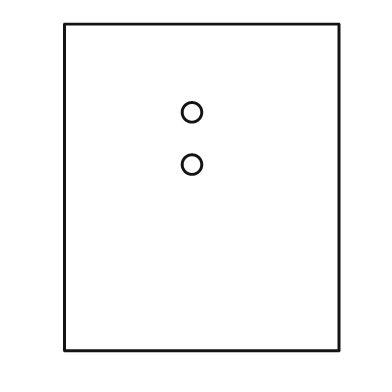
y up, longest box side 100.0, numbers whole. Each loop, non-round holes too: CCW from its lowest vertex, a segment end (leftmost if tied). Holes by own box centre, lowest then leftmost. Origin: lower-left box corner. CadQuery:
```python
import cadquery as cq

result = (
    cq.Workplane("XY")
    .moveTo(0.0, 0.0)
    .lineTo(84.0, 0.0)
    .lineTo(84.0, 100.0)
    .lineTo(0.0, 100.0)
    .close()
    .moveTo(39.0, 57.0)
    .circle(3.0)
    .moveTo(39.0, 73.0)
    .circle(3.0)
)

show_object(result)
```